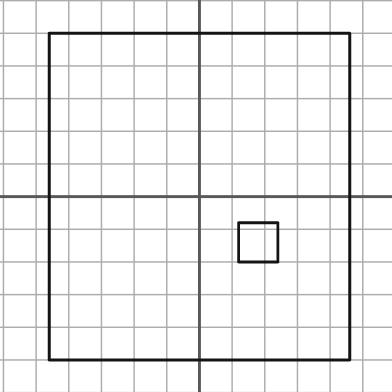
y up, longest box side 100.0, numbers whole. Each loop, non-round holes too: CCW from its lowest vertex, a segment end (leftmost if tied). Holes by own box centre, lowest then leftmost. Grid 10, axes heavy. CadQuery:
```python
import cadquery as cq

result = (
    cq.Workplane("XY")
    .moveTo(-46.0, -50.0)
    .lineTo(46.0, -50.0)
    .lineTo(46.0, 50.0)
    .lineTo(-46.0, 50.0)
    .close()
    .moveTo(12.0, -20.0)
    .lineTo(24.0, -20.0)
    .lineTo(24.0, -8.0)
    .lineTo(12.0, -8.0)
    .close()
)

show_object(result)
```